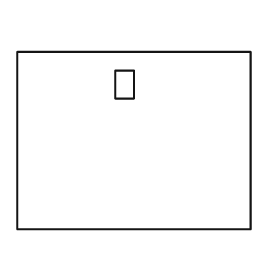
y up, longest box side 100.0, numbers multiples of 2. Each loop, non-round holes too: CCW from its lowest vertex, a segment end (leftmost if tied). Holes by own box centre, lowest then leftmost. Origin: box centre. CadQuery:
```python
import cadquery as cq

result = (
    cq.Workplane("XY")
    .moveTo(-50.0, -38.0)
    .lineTo(50.0, -38.0)
    .lineTo(50.0, 38.0)
    .lineTo(-50.0, 38.0)
    .close()
    .moveTo(-8.0, 18.0)
    .lineTo(0.0, 18.0)
    .lineTo(0.0, 30.0)
    .lineTo(-8.0, 30.0)
    .close()
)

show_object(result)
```